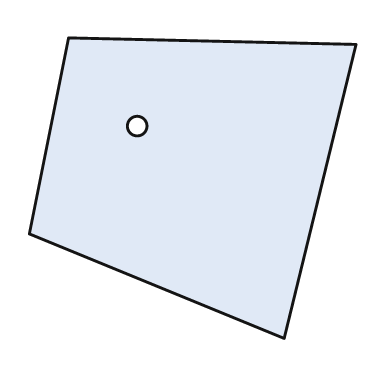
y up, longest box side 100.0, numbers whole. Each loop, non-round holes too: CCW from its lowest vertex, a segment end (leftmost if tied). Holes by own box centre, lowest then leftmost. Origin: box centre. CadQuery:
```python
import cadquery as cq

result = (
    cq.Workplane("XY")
    .moveTo(28.0, -46.0)
    .lineTo(50.0, 44.0)
    .lineTo(-38.0, 46.0)
    .lineTo(-50.0, -14.0)
    .close()
    .moveTo(-17.0, 19.0)
    .circle(3.0)
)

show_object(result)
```